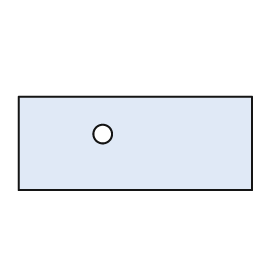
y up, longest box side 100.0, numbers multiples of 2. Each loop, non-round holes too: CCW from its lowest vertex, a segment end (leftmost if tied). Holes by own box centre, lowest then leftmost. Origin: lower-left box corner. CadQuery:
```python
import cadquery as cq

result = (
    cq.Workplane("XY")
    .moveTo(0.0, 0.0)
    .lineTo(100.0, 0.0)
    .lineTo(100.0, 40.0)
    .lineTo(0.0, 40.0)
    .close()
    .moveTo(36.0, 24.0)
    .circle(4.0)
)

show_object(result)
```